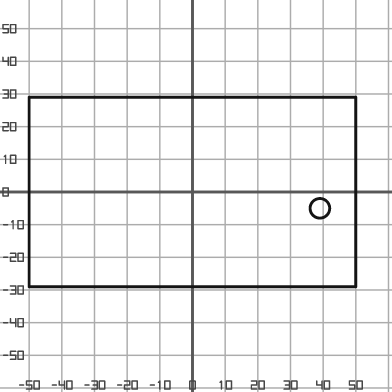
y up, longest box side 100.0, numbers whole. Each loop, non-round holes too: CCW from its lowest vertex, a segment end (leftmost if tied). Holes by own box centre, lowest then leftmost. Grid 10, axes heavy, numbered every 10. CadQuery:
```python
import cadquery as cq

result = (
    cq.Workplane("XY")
    .moveTo(-50.0, -29.0)
    .lineTo(50.0, -29.0)
    .lineTo(50.0, 29.0)
    .lineTo(-50.0, 29.0)
    .close()
    .moveTo(39.0, -5.0)
    .circle(3.0)
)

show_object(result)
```